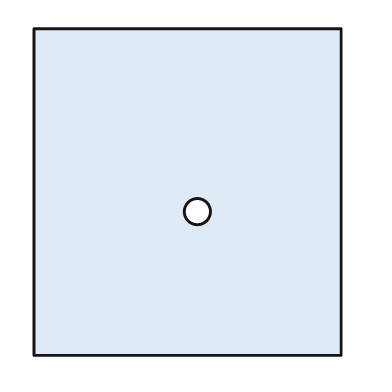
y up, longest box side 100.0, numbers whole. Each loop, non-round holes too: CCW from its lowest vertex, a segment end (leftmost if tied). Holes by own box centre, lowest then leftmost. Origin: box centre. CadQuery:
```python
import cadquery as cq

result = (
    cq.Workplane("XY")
    .moveTo(-47.0, -50.0)
    .lineTo(47.0, -50.0)
    .lineTo(47.0, 50.0)
    .lineTo(-47.0, 50.0)
    .close()
    .moveTo(3.0, -6.0)
    .circle(4.0)
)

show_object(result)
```